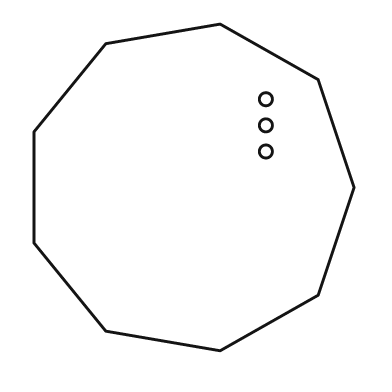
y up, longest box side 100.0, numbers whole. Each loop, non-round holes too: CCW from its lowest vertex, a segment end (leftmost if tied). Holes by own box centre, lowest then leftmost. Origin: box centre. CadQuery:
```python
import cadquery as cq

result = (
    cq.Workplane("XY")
    .moveTo(8.0, -50.0)
    .lineTo(38.0, -33.0)
    .lineTo(49.0, 0.0)
    .lineTo(38.0, 33.0)
    .lineTo(8.0, 50.0)
    .lineTo(-27.0, 44.0)
    .lineTo(-49.0, 17.0)
    .lineTo(-49.0, -17.0)
    .lineTo(-27.0, -44.0)
    .close()
    .moveTo(22.0, 11.0)
    .circle(2.0)
    .moveTo(22.0, 19.0)
    .circle(2.0)
    .moveTo(22.0, 27.0)
    .circle(2.0)
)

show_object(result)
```